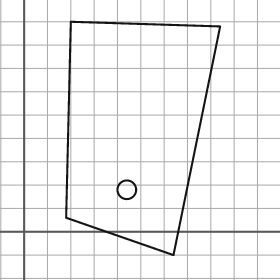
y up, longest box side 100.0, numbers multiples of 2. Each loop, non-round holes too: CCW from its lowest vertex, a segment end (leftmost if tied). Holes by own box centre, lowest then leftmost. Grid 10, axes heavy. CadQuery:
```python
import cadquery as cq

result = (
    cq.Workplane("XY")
    .moveTo(64.0, -10.0)
    .lineTo(84.0, 88.0)
    .lineTo(20.0, 90.0)
    .lineTo(18.0, 6.0)
    .close()
    .moveTo(44.0, 18.0)
    .circle(4.0)
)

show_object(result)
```